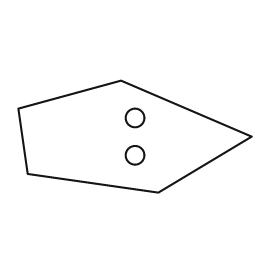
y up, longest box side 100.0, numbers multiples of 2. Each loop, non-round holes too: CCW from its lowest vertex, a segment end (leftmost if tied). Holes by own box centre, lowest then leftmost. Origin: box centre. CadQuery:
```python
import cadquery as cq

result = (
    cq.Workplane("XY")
    .moveTo(10.0, -24.0)
    .lineTo(50.0, 0.0)
    .lineTo(-6.0, 24.0)
    .lineTo(-50.0, 12.0)
    .lineTo(-46.0, -16.0)
    .close()
    .moveTo(0.0, -8.0)
    .circle(4.0)
    .moveTo(0.0, 8.0)
    .circle(4.0)
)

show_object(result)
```